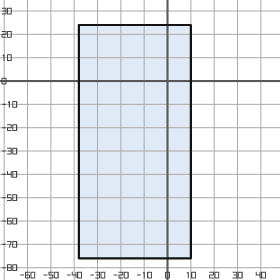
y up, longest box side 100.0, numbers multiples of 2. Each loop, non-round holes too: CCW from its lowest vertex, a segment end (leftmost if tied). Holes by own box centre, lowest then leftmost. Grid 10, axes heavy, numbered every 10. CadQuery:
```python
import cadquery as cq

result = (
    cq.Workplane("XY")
    .moveTo(-38.0, -76.0)
    .lineTo(10.0, -76.0)
    .lineTo(10.0, 24.0)
    .lineTo(-38.0, 24.0)
    .close()
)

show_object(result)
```